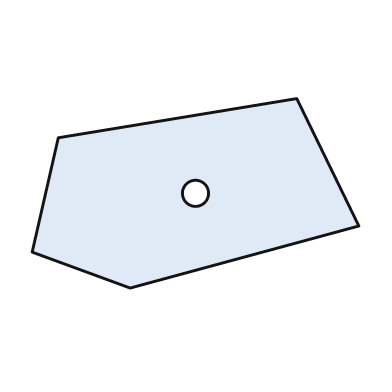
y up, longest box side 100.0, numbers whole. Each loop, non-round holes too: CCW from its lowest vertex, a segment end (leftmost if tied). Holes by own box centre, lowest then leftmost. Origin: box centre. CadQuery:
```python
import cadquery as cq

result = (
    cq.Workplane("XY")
    .moveTo(-20.0, -29.0)
    .lineTo(50.0, -10.0)
    .lineTo(31.0, 29.0)
    .lineTo(-42.0, 17.0)
    .lineTo(-50.0, -18.0)
    .close()
    .moveTo(0.0, 0.0)
    .circle(4.0)
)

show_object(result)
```